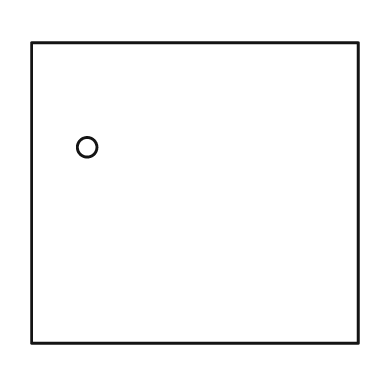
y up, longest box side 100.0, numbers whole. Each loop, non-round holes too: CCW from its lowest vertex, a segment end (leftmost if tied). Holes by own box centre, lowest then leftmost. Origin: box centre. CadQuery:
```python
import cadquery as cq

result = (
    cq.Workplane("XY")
    .moveTo(-50.0, -46.0)
    .lineTo(50.0, -46.0)
    .lineTo(50.0, 46.0)
    .lineTo(-50.0, 46.0)
    .close()
    .moveTo(-33.0, 14.0)
    .circle(3.0)
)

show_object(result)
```